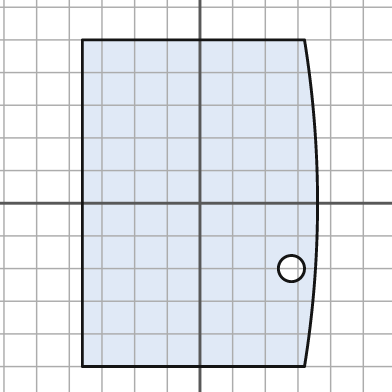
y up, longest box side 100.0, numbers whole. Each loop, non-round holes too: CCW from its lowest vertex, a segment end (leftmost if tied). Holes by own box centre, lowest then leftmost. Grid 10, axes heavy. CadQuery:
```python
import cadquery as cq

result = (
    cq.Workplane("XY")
    .moveTo(-36.0, -50.0)
    .lineTo(32.0, -50.0)
    .threePointArc((36.0, 0.0), (32.0, 50.0))
    .lineTo(-36.0, 50.0)
    .close()
    .moveTo(28.0, -20.0)
    .circle(4.0)
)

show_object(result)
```